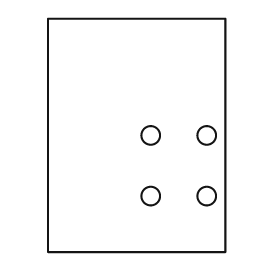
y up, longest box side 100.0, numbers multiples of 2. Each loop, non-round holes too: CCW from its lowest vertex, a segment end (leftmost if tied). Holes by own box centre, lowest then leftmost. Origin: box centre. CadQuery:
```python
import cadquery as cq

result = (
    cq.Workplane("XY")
    .moveTo(-38.0, -50.0)
    .lineTo(38.0, -50.0)
    .lineTo(38.0, 50.0)
    .lineTo(-38.0, 50.0)
    .close()
    .moveTo(6.0, -26.0)
    .circle(4.0)
    .moveTo(30.0, -26.0)
    .circle(4.0)
    .moveTo(6.0, 0.0)
    .circle(4.0)
    .moveTo(30.0, 0.0)
    .circle(4.0)
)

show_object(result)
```